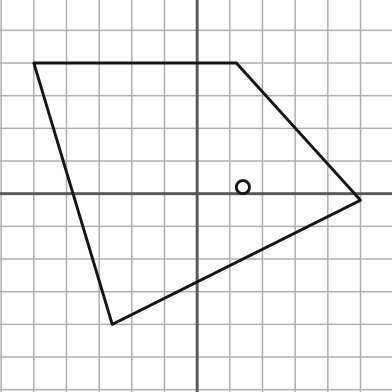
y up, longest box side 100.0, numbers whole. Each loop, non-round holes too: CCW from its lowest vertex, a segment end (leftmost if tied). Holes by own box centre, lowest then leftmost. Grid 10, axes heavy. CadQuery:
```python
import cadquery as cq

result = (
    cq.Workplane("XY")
    .moveTo(-26.0, -40.0)
    .lineTo(50.0, -2.0)
    .lineTo(12.0, 40.0)
    .lineTo(-50.0, 40.0)
    .close()
    .moveTo(14.0, 2.0)
    .circle(2.0)
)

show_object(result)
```